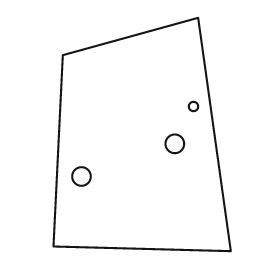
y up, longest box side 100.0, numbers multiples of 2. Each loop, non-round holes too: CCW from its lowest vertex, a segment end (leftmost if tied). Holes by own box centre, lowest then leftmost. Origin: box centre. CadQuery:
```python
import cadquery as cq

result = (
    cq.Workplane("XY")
    .moveTo(38.0, -50.0)
    .lineTo(24.0, 50.0)
    .lineTo(-34.0, 34.0)
    .lineTo(-38.0, -48.0)
    .close()
    .moveTo(-26.0, -18.0)
    .circle(4.0)
    .moveTo(14.0, -4.0)
    .circle(4.0)
    .moveTo(22.0, 12.0)
    .circle(2.0)
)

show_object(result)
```